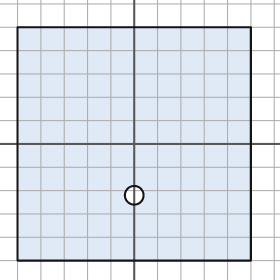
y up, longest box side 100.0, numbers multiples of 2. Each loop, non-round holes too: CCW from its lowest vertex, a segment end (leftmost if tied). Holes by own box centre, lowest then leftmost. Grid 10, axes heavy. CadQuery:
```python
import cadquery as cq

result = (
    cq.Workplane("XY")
    .moveTo(-50.0, -50.0)
    .lineTo(50.0, -50.0)
    .lineTo(50.0, 50.0)
    .lineTo(-50.0, 50.0)
    .close()
    .moveTo(0.0, -22.0)
    .circle(4.0)
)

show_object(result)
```